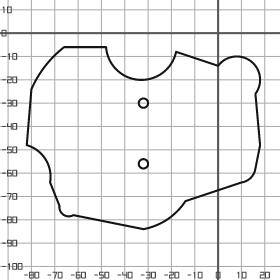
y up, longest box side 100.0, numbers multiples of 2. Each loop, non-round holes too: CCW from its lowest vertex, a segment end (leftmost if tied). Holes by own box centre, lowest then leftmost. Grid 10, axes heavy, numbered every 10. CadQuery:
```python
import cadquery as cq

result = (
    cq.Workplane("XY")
    .moveTo(-32.0, -84.0)
    .threePointArc((-22.0, -80.0), (-14.0, -72.0))
    .lineTo(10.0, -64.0)
    .threePointArc((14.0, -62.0), (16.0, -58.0))
    .lineTo(18.0, -48.0)
    .lineTo(16.0, -26.0)
    .threePointArc((14.0, -12.0), (0.0, -14.0))
    .lineTo(-18.0, -8.0)
    .threePointArc((-34.0, -20.0), (-48.0, -6.0))
    .lineTo(-66.0, -6.0)
    .threePointArc((-74.0, -14.0), (-80.0, -24.0))
    .lineTo(-82.0, -48.0)
    .threePointArc((-74.0, -54.0), (-72.0, -64.0))
    .lineTo(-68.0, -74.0)
    .threePointArc((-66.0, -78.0), (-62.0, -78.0))
    .close()
    .moveTo(-32.0, -56.0)
    .circle(2.0)
    .moveTo(-32.0, -30.0)
    .circle(2.0)
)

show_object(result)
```